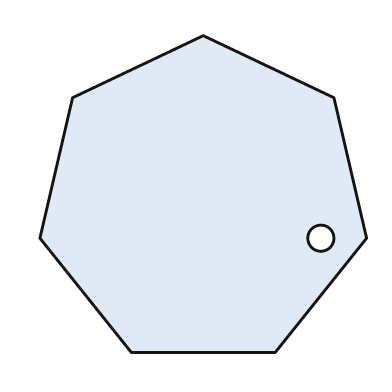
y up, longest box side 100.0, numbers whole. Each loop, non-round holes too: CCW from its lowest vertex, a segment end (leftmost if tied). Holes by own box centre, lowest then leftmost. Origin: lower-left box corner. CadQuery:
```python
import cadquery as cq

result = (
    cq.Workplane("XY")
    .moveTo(28.0, 0.0)
    .lineTo(72.0, 0.0)
    .lineTo(100.0, 35.0)
    .lineTo(90.0, 78.0)
    .lineTo(50.0, 97.0)
    .lineTo(10.0, 78.0)
    .lineTo(0.0, 35.0)
    .close()
    .moveTo(86.0, 35.0)
    .circle(4.0)
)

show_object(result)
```